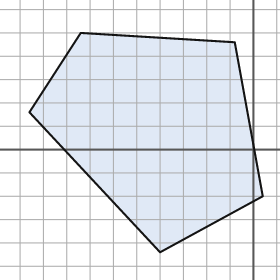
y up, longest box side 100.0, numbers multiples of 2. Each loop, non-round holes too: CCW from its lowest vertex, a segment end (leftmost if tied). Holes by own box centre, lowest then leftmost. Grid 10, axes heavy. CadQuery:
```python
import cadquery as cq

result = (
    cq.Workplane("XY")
    .moveTo(-40.0, -44.0)
    .lineTo(4.0, -20.0)
    .lineTo(-8.0, 46.0)
    .lineTo(-74.0, 50.0)
    .lineTo(-96.0, 16.0)
    .close()
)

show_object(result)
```